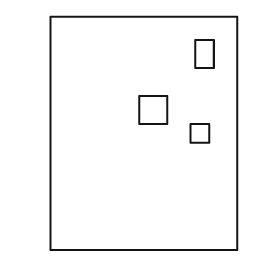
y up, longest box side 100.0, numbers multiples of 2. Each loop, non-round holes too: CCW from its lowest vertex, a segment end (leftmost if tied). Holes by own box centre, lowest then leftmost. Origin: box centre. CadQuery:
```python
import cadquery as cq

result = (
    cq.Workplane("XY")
    .moveTo(-40.0, -50.0)
    .lineTo(40.0, -50.0)
    .lineTo(40.0, 50.0)
    .lineTo(-40.0, 50.0)
    .close()
    .moveTo(20.0, -4.0)
    .lineTo(28.0, -4.0)
    .lineTo(28.0, 4.0)
    .lineTo(20.0, 4.0)
    .close()
    .moveTo(-2.0, 4.0)
    .lineTo(10.0, 4.0)
    .lineTo(10.0, 16.0)
    .lineTo(-2.0, 16.0)
    .close()
    .moveTo(22.0, 28.0)
    .lineTo(30.0, 28.0)
    .lineTo(30.0, 40.0)
    .lineTo(22.0, 40.0)
    .close()
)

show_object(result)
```